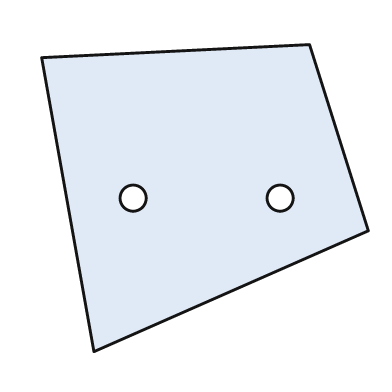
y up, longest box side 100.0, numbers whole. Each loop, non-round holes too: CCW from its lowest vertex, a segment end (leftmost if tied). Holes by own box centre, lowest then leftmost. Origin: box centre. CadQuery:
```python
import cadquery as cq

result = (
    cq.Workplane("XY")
    .moveTo(-34.0, -47.0)
    .lineTo(50.0, -10.0)
    .lineTo(32.0, 47.0)
    .lineTo(-50.0, 43.0)
    .close()
    .moveTo(-22.0, 0.0)
    .circle(4.0)
    .moveTo(23.0, 0.0)
    .circle(4.0)
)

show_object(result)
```